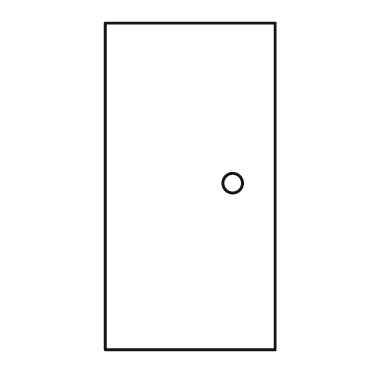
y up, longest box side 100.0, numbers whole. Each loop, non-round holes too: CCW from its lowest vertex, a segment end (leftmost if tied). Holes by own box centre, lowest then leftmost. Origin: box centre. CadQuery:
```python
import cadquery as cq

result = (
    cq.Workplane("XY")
    .moveTo(-26.0, -50.0)
    .lineTo(26.0, -50.0)
    .lineTo(26.0, 50.0)
    .lineTo(-26.0, 50.0)
    .close()
    .moveTo(13.0, 1.0)
    .circle(3.0)
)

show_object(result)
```